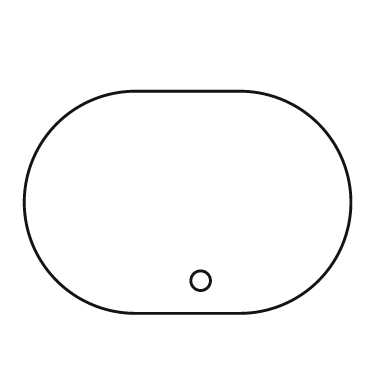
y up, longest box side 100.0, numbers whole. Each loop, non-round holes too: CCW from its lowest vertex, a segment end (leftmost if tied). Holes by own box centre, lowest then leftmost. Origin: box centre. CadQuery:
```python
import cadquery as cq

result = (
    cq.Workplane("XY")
    .moveTo(-16.0, -34.0)
    .lineTo(16.0, -34.0)
    .threePointArc((50.0, 0.0), (16.0, 34.0))
    .lineTo(-16.0, 34.0)
    .threePointArc((-50.0, 0.0), (-16.0, -34.0))
    .close()
    .moveTo(4.0, -24.0)
    .circle(3.0)
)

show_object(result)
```